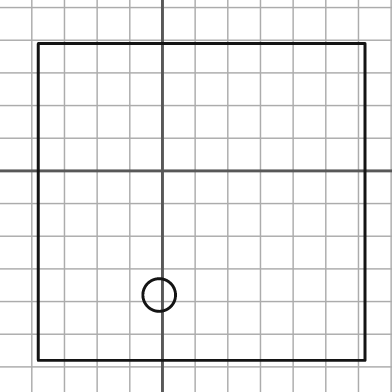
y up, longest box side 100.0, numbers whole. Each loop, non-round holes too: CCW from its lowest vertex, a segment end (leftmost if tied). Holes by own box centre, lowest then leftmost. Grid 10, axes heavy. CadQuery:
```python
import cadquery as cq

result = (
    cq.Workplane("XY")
    .moveTo(-38.0, -58.0)
    .lineTo(62.0, -58.0)
    .lineTo(62.0, 39.0)
    .lineTo(-38.0, 39.0)
    .close()
    .moveTo(-1.0, -38.0)
    .circle(5.0)
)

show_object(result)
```